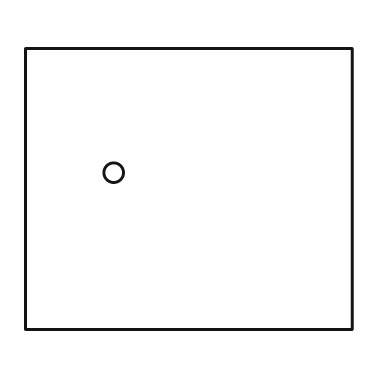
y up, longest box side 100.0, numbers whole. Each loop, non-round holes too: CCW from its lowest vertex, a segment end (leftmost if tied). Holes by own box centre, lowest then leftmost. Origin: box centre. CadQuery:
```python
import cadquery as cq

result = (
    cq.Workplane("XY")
    .moveTo(-50.0, -43.0)
    .lineTo(50.0, -43.0)
    .lineTo(50.0, 43.0)
    .lineTo(-50.0, 43.0)
    .close()
    .moveTo(-23.0, 5.0)
    .circle(3.0)
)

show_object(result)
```